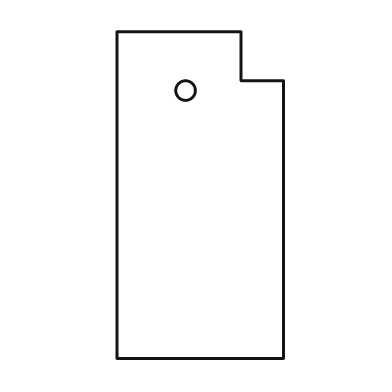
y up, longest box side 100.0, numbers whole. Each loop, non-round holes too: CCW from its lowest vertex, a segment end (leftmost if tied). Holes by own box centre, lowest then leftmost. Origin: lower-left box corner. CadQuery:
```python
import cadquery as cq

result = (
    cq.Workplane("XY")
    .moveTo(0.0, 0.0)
    .lineTo(51.0, 0.0)
    .lineTo(51.0, 85.0)
    .lineTo(38.0, 85.0)
    .lineTo(38.0, 100.0)
    .lineTo(0.0, 100.0)
    .close()
    .moveTo(21.0, 82.0)
    .circle(3.0)
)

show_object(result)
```